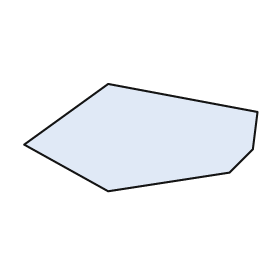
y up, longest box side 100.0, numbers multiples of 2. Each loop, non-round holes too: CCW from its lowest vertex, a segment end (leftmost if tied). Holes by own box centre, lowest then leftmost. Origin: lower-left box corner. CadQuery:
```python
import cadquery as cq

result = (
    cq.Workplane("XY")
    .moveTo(36.0, 0.0)
    .lineTo(88.0, 8.0)
    .lineTo(98.0, 18.0)
    .lineTo(100.0, 34.0)
    .lineTo(36.0, 46.0)
    .lineTo(0.0, 20.0)
    .close()
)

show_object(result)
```